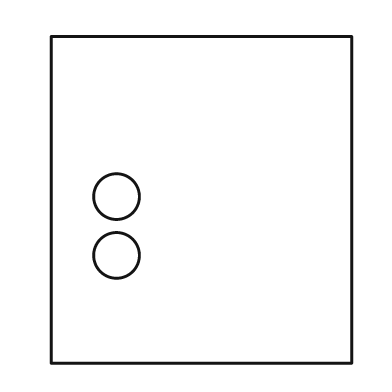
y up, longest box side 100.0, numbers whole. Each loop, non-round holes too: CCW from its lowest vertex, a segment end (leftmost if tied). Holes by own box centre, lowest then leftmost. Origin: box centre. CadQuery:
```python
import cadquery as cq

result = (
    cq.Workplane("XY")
    .moveTo(-46.0, -50.0)
    .lineTo(46.0, -50.0)
    .lineTo(46.0, 50.0)
    .lineTo(-46.0, 50.0)
    .close()
    .moveTo(-26.0, -17.0)
    .circle(7.0)
    .moveTo(-26.0, 1.0)
    .circle(7.0)
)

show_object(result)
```